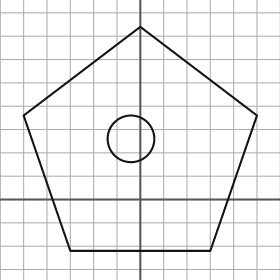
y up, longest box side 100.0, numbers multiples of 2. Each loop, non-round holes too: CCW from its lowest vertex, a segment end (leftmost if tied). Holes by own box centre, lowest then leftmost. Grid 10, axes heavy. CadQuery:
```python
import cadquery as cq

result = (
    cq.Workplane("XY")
    .moveTo(-30.0, -22.0)
    .lineTo(30.0, -22.0)
    .lineTo(50.0, 36.0)
    .lineTo(0.0, 74.0)
    .lineTo(-50.0, 36.0)
    .close()
    .moveTo(-4.0, 26.0)
    .circle(10.0)
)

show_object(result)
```